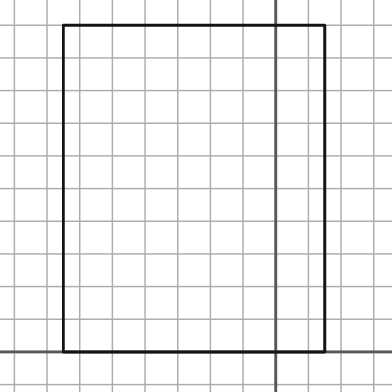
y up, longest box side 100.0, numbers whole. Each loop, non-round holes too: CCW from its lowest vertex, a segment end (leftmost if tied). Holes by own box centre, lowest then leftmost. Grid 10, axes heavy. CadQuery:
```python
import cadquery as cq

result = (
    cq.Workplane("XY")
    .moveTo(-65.0, 0.0)
    .lineTo(15.0, 0.0)
    .lineTo(15.0, 100.0)
    .lineTo(-65.0, 100.0)
    .close()
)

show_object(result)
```